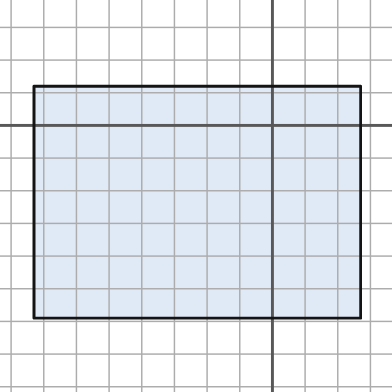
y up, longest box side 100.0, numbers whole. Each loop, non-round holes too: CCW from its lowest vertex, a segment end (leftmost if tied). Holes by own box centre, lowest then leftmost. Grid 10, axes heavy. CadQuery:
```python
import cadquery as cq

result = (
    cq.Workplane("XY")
    .moveTo(-73.0, -59.0)
    .lineTo(27.0, -59.0)
    .lineTo(27.0, 12.0)
    .lineTo(-73.0, 12.0)
    .close()
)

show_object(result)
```